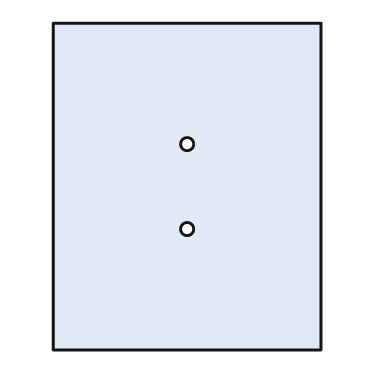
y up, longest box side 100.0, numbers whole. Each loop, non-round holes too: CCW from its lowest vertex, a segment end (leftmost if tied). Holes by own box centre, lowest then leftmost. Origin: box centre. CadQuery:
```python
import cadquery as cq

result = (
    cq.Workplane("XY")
    .moveTo(-41.0, -50.0)
    .lineTo(41.0, -50.0)
    .lineTo(41.0, 50.0)
    .lineTo(-41.0, 50.0)
    .close()
    .moveTo(0.0, -13.0)
    .circle(2.0)
    .moveTo(0.0, 13.0)
    .circle(2.0)
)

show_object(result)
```